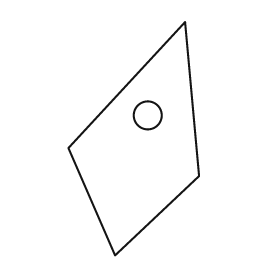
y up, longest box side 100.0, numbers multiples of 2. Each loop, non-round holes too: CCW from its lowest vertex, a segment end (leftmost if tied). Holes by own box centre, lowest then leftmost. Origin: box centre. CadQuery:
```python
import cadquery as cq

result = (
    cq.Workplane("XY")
    .moveTo(-8.0, -50.0)
    .lineTo(28.0, -16.0)
    .lineTo(22.0, 50.0)
    .lineTo(-28.0, -4.0)
    .close()
    .moveTo(6.0, 10.0)
    .circle(6.0)
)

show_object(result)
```